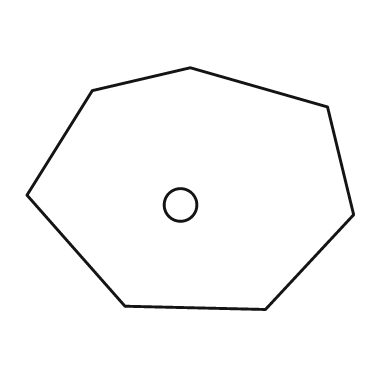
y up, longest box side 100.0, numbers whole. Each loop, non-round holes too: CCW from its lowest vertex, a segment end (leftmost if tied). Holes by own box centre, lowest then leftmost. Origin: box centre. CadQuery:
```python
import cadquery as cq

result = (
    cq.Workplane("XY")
    .moveTo(23.0, -37.0)
    .lineTo(50.0, -8.0)
    .lineTo(42.0, 25.0)
    .lineTo(0.0, 37.0)
    .lineTo(-30.0, 30.0)
    .lineTo(-50.0, -2.0)
    .lineTo(-20.0, -36.0)
    .close()
    .moveTo(-3.0, -5.0)
    .circle(5.0)
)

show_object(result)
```